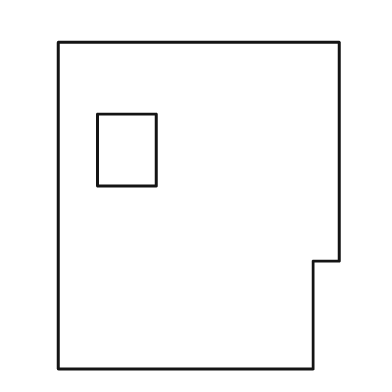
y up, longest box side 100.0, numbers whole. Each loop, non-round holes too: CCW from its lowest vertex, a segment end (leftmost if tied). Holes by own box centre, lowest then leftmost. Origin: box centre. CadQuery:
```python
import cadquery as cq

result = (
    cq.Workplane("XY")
    .moveTo(-43.0, -50.0)
    .lineTo(35.0, -50.0)
    .lineTo(35.0, -17.0)
    .lineTo(43.0, -17.0)
    .lineTo(43.0, 50.0)
    .lineTo(-43.0, 50.0)
    .close()
    .moveTo(-31.0, 6.0)
    .lineTo(-13.0, 6.0)
    .lineTo(-13.0, 28.0)
    .lineTo(-31.0, 28.0)
    .close()
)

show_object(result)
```